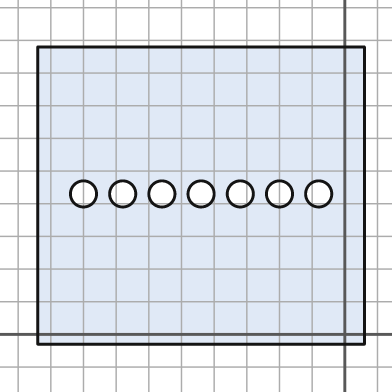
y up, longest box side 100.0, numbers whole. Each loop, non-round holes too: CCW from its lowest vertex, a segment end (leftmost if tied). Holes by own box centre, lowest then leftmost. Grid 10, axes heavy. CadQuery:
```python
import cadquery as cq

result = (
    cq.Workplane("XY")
    .moveTo(-94.0, -3.0)
    .lineTo(6.0, -3.0)
    .lineTo(6.0, 88.0)
    .lineTo(-94.0, 88.0)
    .close()
    .moveTo(-80.0, 43.0)
    .circle(4.0)
    .moveTo(-68.0, 43.0)
    .circle(4.0)
    .moveTo(-56.0, 43.0)
    .circle(4.0)
    .moveTo(-44.0, 43.0)
    .circle(4.0)
    .moveTo(-32.0, 43.0)
    .circle(4.0)
    .moveTo(-20.0, 43.0)
    .circle(4.0)
    .moveTo(-8.0, 43.0)
    .circle(4.0)
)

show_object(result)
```